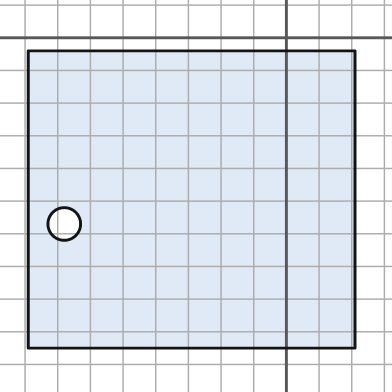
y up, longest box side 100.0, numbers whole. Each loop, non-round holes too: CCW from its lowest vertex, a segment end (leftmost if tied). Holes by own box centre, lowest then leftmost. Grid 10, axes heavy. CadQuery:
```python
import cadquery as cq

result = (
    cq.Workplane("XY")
    .moveTo(-79.0, -95.0)
    .lineTo(21.0, -95.0)
    .lineTo(21.0, -4.0)
    .lineTo(-79.0, -4.0)
    .close()
    .moveTo(-68.0, -57.0)
    .circle(5.0)
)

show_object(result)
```